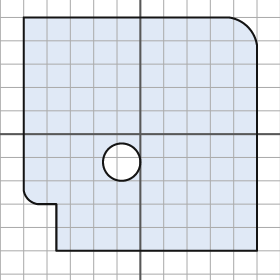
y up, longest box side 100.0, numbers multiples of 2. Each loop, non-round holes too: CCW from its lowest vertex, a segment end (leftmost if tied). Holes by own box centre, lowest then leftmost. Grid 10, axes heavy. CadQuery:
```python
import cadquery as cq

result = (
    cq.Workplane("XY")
    .moveTo(-36.0, -50.0)
    .lineTo(50.0, -50.0)
    .lineTo(50.0, 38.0)
    .threePointArc((46.0, 46.0), (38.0, 50.0))
    .lineTo(-50.0, 50.0)
    .lineTo(-50.0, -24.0)
    .threePointArc((-48.0, -28.0), (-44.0, -30.0))
    .lineTo(-36.0, -30.0)
    .close()
    .moveTo(-8.0, -12.0)
    .circle(8.0)
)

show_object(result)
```